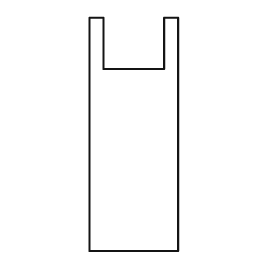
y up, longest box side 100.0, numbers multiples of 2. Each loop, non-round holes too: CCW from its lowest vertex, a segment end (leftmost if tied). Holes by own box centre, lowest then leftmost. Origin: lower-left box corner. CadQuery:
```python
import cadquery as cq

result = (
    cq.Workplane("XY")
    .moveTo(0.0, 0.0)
    .lineTo(38.0, 0.0)
    .lineTo(38.0, 100.0)
    .lineTo(32.0, 100.0)
    .lineTo(32.0, 78.0)
    .lineTo(6.0, 78.0)
    .lineTo(6.0, 100.0)
    .lineTo(0.0, 100.0)
    .close()
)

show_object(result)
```